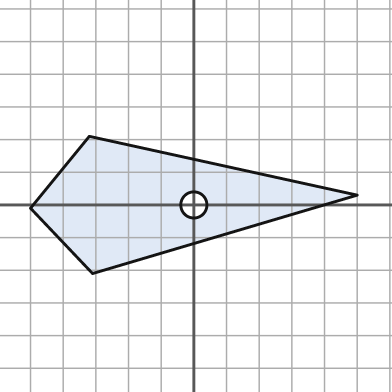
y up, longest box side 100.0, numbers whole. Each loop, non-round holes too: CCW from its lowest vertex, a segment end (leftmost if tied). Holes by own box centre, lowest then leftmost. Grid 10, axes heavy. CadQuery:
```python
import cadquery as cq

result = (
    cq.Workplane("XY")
    .moveTo(-31.0, -21.0)
    .lineTo(50.0, 3.0)
    .lineTo(-32.0, 21.0)
    .lineTo(-50.0, -1.0)
    .close()
    .moveTo(0.0, 0.0)
    .circle(4.0)
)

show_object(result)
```